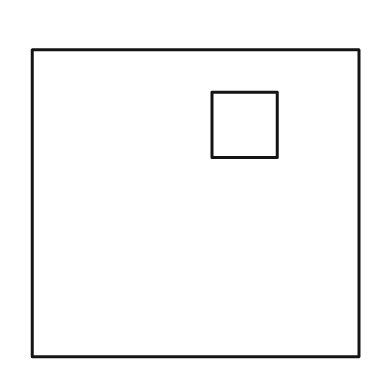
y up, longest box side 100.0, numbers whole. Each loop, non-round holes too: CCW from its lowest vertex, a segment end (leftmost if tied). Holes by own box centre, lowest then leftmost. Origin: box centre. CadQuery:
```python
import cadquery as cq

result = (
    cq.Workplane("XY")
    .moveTo(-50.0, -47.0)
    .lineTo(50.0, -47.0)
    .lineTo(50.0, 47.0)
    .lineTo(-50.0, 47.0)
    .close()
    .moveTo(5.0, 14.0)
    .lineTo(25.0, 14.0)
    .lineTo(25.0, 34.0)
    .lineTo(5.0, 34.0)
    .close()
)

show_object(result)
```